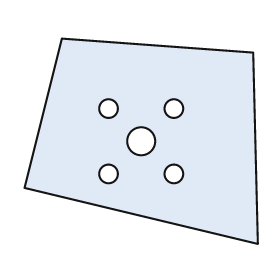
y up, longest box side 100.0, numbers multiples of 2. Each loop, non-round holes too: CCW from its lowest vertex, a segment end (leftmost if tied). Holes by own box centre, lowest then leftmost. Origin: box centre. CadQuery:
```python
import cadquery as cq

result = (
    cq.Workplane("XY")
    .moveTo(50.0, -44.0)
    .lineTo(48.0, 38.0)
    .lineTo(-34.0, 44.0)
    .lineTo(-50.0, -20.0)
    .close()
    .moveTo(-14.0, -14.0)
    .circle(4.0)
    .moveTo(14.0, -14.0)
    .circle(4.0)
    .moveTo(0.0, 0.0)
    .circle(6.0)
    .moveTo(-14.0, 14.0)
    .circle(4.0)
    .moveTo(14.0, 14.0)
    .circle(4.0)
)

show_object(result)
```